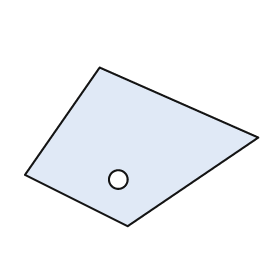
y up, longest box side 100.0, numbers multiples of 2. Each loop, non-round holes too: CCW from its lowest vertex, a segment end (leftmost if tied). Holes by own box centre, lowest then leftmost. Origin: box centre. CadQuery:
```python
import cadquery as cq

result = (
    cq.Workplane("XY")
    .moveTo(-6.0, -34.0)
    .lineTo(50.0, 4.0)
    .lineTo(-18.0, 34.0)
    .lineTo(-50.0, -12.0)
    .close()
    .moveTo(-10.0, -14.0)
    .circle(4.0)
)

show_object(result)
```